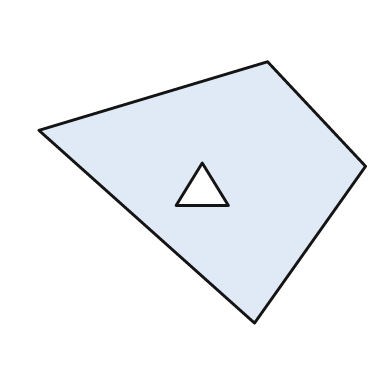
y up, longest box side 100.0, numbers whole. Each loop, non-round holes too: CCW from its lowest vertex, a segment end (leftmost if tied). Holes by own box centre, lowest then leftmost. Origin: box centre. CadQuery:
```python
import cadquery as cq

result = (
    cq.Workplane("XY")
    .moveTo(16.0, -40.0)
    .lineTo(50.0, 8.0)
    .lineTo(20.0, 40.0)
    .lineTo(-50.0, 19.0)
    .close()
    .moveTo(-8.0, -4.0)
    .lineTo(8.0, -4.0)
    .lineTo(0.0, 9.0)
    .close()
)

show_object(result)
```